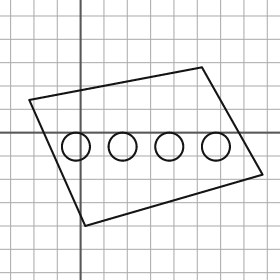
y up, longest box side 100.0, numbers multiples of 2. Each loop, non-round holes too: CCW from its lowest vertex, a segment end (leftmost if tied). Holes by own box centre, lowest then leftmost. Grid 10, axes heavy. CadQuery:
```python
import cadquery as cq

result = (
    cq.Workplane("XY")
    .moveTo(2.0, -40.0)
    .lineTo(78.0, -18.0)
    .lineTo(52.0, 28.0)
    .lineTo(-22.0, 14.0)
    .close()
    .moveTo(-2.0, -6.0)
    .circle(6.0)
    .moveTo(18.0, -6.0)
    .circle(6.0)
    .moveTo(38.0, -6.0)
    .circle(6.0)
    .moveTo(58.0, -6.0)
    .circle(6.0)
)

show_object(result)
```